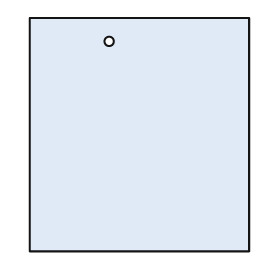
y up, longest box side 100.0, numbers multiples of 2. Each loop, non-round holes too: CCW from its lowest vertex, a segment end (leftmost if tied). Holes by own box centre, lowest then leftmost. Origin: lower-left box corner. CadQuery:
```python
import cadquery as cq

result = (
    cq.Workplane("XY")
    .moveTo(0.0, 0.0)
    .lineTo(94.0, 0.0)
    .lineTo(94.0, 100.0)
    .lineTo(0.0, 100.0)
    .close()
    .moveTo(34.0, 90.0)
    .circle(2.0)
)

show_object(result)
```